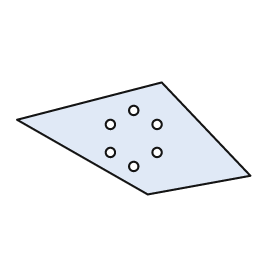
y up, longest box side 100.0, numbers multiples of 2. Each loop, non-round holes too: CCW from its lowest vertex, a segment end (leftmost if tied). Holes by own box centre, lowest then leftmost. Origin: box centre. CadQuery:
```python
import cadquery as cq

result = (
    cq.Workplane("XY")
    .moveTo(6.0, -24.0)
    .lineTo(50.0, -16.0)
    .lineTo(12.0, 24.0)
    .lineTo(-50.0, 8.0)
    .close()
    .moveTo(0.0, -12.0)
    .circle(2.0)
    .moveTo(-10.0, -6.0)
    .circle(2.0)
    .moveTo(10.0, -6.0)
    .circle(2.0)
    .moveTo(-10.0, 6.0)
    .circle(2.0)
    .moveTo(10.0, 6.0)
    .circle(2.0)
    .moveTo(0.0, 12.0)
    .circle(2.0)
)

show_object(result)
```